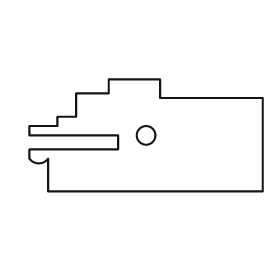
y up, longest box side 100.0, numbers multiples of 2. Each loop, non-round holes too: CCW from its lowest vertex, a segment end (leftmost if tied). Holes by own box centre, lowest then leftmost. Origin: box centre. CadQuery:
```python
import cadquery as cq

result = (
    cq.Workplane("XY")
    .moveTo(-42.0, -24.0)
    .lineTo(50.0, -24.0)
    .lineTo(50.0, 16.0)
    .lineTo(6.0, 16.0)
    .lineTo(6.0, 24.0)
    .lineTo(-16.0, 24.0)
    .lineTo(-16.0, 18.0)
    .lineTo(-30.0, 18.0)
    .lineTo(-30.0, 8.0)
    .lineTo(-38.0, 8.0)
    .lineTo(-38.0, 4.0)
    .lineTo(-50.0, 4.0)
    .lineTo(-50.0, 0.0)
    .lineTo(-12.0, 0.0)
    .lineTo(-12.0, -6.0)
    .lineTo(-50.0, -6.0)
    .lineTo(-50.0, -10.0)
    .threePointArc((-46.0, -12.0), (-42.0, -10.0))
    .close()
    .moveTo(0.0, 0.0)
    .circle(4.0)
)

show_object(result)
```